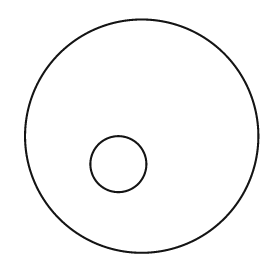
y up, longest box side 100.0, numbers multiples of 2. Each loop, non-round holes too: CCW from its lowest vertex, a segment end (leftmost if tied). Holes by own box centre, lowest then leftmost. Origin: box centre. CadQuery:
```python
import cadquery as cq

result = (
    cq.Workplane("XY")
    .moveTo(0.0, 0.0)
    .circle(50.0)
    .moveTo(-10.0, -12.0)
    .circle(12.0)
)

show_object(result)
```